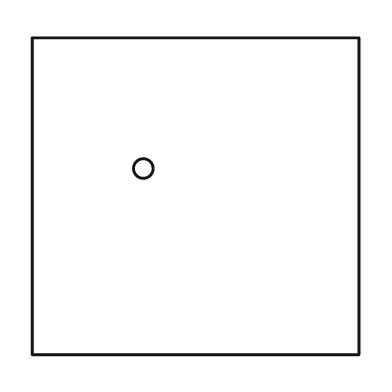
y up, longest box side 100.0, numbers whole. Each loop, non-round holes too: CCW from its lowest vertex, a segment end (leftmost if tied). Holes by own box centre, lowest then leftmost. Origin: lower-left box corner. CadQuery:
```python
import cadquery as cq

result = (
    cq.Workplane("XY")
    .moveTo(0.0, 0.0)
    .lineTo(100.0, 0.0)
    .lineTo(100.0, 97.0)
    .lineTo(0.0, 97.0)
    .close()
    .moveTo(34.0, 57.0)
    .circle(3.0)
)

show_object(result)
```